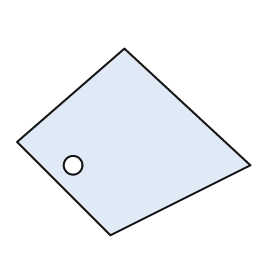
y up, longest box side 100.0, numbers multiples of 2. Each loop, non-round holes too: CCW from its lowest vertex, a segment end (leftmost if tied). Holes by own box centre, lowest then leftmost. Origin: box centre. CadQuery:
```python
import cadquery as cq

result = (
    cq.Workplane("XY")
    .moveTo(-10.0, -40.0)
    .lineTo(50.0, -10.0)
    .lineTo(-4.0, 40.0)
    .lineTo(-50.0, 0.0)
    .close()
    .moveTo(-26.0, -10.0)
    .circle(4.0)
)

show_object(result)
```